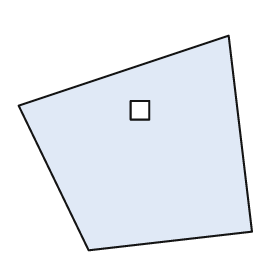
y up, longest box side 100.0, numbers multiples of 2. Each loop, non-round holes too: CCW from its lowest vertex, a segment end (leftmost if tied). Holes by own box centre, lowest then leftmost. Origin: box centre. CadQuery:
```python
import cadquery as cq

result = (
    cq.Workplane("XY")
    .moveTo(-20.0, -46.0)
    .lineTo(50.0, -38.0)
    .lineTo(40.0, 46.0)
    .lineTo(-50.0, 16.0)
    .close()
    .moveTo(-2.0, 10.0)
    .lineTo(6.0, 10.0)
    .lineTo(6.0, 18.0)
    .lineTo(-2.0, 18.0)
    .close()
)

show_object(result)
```